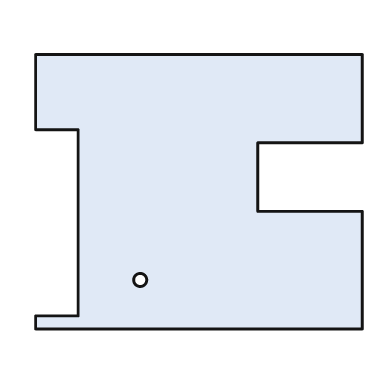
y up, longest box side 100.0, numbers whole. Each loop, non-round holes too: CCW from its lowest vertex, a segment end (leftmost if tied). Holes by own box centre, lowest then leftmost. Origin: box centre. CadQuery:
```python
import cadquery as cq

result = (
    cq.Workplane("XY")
    .moveTo(-50.0, -42.0)
    .lineTo(50.0, -42.0)
    .lineTo(50.0, -6.0)
    .lineTo(18.0, -6.0)
    .lineTo(18.0, 15.0)
    .lineTo(50.0, 15.0)
    .lineTo(50.0, 42.0)
    .lineTo(-50.0, 42.0)
    .lineTo(-50.0, 19.0)
    .lineTo(-37.0, 19.0)
    .lineTo(-37.0, -38.0)
    .lineTo(-50.0, -38.0)
    .close()
    .moveTo(-18.0, -27.0)
    .circle(2.0)
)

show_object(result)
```